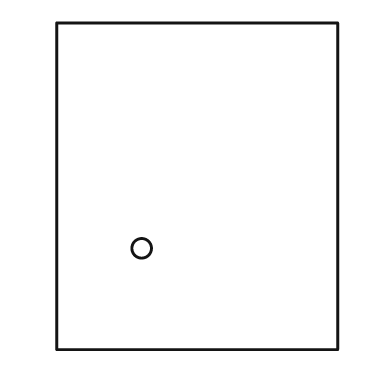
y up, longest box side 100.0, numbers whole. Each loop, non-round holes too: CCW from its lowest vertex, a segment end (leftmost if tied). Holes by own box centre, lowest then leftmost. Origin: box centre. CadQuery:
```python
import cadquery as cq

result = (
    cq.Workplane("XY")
    .moveTo(-43.0, -50.0)
    .lineTo(43.0, -50.0)
    .lineTo(43.0, 50.0)
    .lineTo(-43.0, 50.0)
    .close()
    .moveTo(-17.0, -19.0)
    .circle(3.0)
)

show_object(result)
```